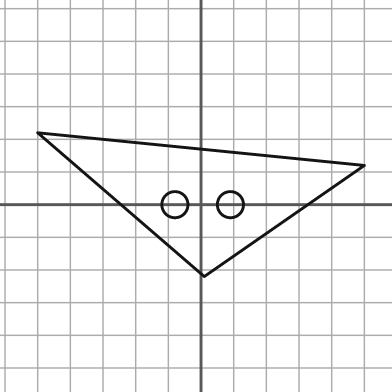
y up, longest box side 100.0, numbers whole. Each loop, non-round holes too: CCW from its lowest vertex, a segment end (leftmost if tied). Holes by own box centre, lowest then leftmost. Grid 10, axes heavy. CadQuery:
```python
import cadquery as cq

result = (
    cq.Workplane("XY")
    .moveTo(1.0, -22.0)
    .lineTo(50.0, 12.0)
    .lineTo(-50.0, 22.0)
    .close()
    .moveTo(-8.0, 0.0)
    .circle(4.0)
    .moveTo(9.0, 0.0)
    .circle(4.0)
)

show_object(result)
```